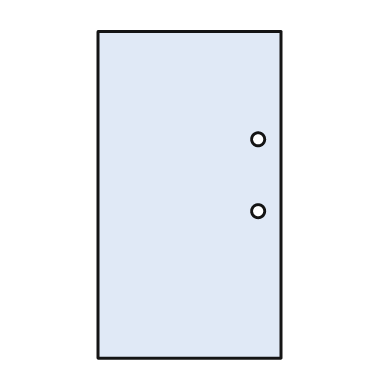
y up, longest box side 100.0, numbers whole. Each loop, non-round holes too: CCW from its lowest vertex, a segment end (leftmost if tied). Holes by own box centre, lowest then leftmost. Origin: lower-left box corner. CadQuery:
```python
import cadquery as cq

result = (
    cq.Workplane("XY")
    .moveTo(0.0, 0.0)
    .lineTo(56.0, 0.0)
    .lineTo(56.0, 100.0)
    .lineTo(0.0, 100.0)
    .close()
    .moveTo(49.0, 45.0)
    .circle(2.0)
    .moveTo(49.0, 67.0)
    .circle(2.0)
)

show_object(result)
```